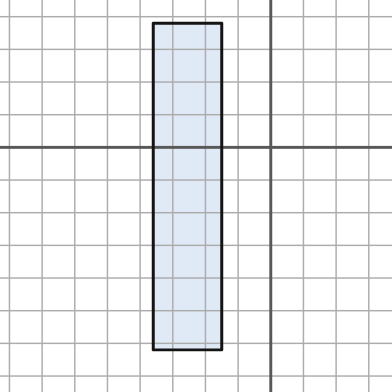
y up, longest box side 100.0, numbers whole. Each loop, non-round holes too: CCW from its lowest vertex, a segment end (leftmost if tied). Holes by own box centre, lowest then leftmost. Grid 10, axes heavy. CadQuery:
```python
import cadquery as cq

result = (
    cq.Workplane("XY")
    .moveTo(-36.0, -62.0)
    .lineTo(-15.0, -62.0)
    .lineTo(-15.0, 38.0)
    .lineTo(-36.0, 38.0)
    .close()
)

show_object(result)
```